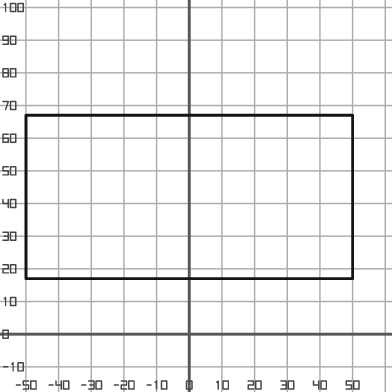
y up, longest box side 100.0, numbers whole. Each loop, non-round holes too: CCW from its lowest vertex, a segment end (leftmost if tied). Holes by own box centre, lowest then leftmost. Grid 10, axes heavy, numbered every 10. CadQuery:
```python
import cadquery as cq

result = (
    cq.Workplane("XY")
    .moveTo(-50.0, 17.0)
    .lineTo(50.0, 17.0)
    .lineTo(50.0, 67.0)
    .lineTo(-50.0, 67.0)
    .close()
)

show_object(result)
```